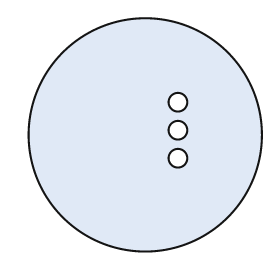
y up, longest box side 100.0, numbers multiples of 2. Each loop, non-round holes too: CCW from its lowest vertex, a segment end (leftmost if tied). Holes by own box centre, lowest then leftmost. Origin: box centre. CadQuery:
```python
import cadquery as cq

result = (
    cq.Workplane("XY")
    .moveTo(0.0, 0.0)
    .circle(50.0)
    .moveTo(14.0, -10.0)
    .circle(4.0)
    .moveTo(14.0, 2.0)
    .circle(4.0)
    .moveTo(14.0, 14.0)
    .circle(4.0)
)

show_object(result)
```